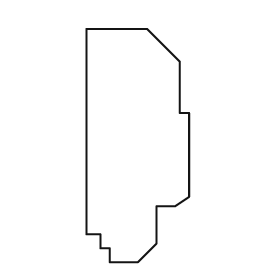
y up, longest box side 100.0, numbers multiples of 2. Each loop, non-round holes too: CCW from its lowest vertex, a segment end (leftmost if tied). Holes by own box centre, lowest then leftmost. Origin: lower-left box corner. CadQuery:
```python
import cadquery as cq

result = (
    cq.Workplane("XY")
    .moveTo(10.0, 0.0)
    .lineTo(22.0, 0.0)
    .lineTo(30.0, 8.0)
    .lineTo(30.0, 24.0)
    .lineTo(38.0, 24.0)
    .lineTo(44.0, 28.0)
    .lineTo(44.0, 64.0)
    .lineTo(40.0, 64.0)
    .lineTo(40.0, 86.0)
    .lineTo(26.0, 100.0)
    .lineTo(0.0, 100.0)
    .lineTo(0.0, 12.0)
    .lineTo(6.0, 12.0)
    .lineTo(6.0, 6.0)
    .lineTo(10.0, 6.0)
    .close()
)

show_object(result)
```